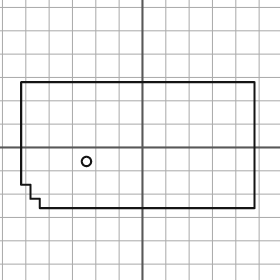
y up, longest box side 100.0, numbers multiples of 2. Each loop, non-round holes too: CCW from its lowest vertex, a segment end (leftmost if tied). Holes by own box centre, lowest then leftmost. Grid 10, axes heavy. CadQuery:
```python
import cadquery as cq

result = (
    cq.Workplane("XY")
    .moveTo(-44.0, -26.0)
    .lineTo(48.0, -26.0)
    .lineTo(48.0, 28.0)
    .lineTo(-52.0, 28.0)
    .lineTo(-52.0, -16.0)
    .lineTo(-48.0, -16.0)
    .lineTo(-48.0, -22.0)
    .lineTo(-44.0, -22.0)
    .close()
    .moveTo(-24.0, -6.0)
    .circle(2.0)
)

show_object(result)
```